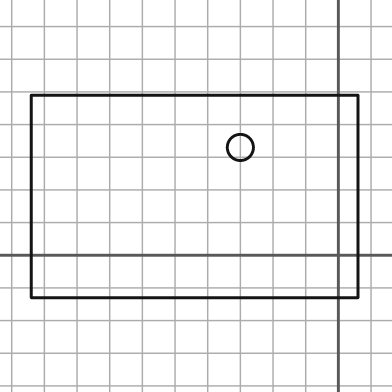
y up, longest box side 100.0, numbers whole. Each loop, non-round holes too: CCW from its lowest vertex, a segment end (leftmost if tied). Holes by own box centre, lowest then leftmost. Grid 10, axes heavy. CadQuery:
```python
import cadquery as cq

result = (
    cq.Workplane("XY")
    .moveTo(-94.0, -13.0)
    .lineTo(6.0, -13.0)
    .lineTo(6.0, 49.0)
    .lineTo(-94.0, 49.0)
    .close()
    .moveTo(-30.0, 33.0)
    .circle(4.0)
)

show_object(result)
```